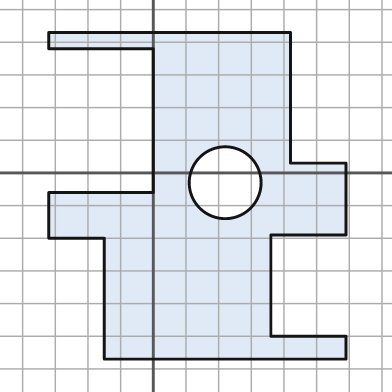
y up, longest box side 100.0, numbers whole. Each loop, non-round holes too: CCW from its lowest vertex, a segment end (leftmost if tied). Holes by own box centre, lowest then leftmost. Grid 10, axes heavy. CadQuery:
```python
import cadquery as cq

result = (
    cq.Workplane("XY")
    .moveTo(-15.0, -57.0)
    .lineTo(59.0, -57.0)
    .lineTo(59.0, -50.0)
    .lineTo(36.0, -50.0)
    .lineTo(36.0, -19.0)
    .lineTo(59.0, -19.0)
    .lineTo(59.0, 3.0)
    .lineTo(42.0, 3.0)
    .lineTo(42.0, 43.0)
    .lineTo(-32.0, 43.0)
    .lineTo(-32.0, 38.0)
    .lineTo(0.0, 38.0)
    .lineTo(0.0, -6.0)
    .lineTo(-32.0, -6.0)
    .lineTo(-32.0, -20.0)
    .lineTo(-15.0, -20.0)
    .close()
    .moveTo(22.0, -3.0)
    .circle(11.0)
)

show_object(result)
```